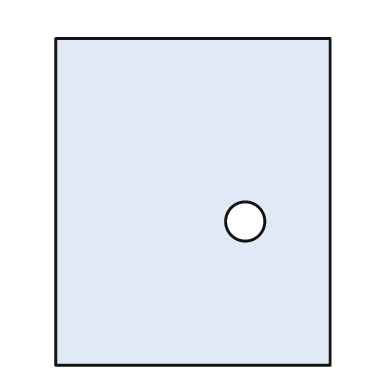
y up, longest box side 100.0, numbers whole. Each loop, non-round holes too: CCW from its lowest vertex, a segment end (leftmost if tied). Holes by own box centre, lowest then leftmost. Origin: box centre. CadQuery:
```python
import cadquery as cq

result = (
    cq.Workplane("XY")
    .moveTo(-42.0, -50.0)
    .lineTo(42.0, -50.0)
    .lineTo(42.0, 50.0)
    .lineTo(-42.0, 50.0)
    .close()
    .moveTo(16.0, -6.0)
    .circle(6.0)
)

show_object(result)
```